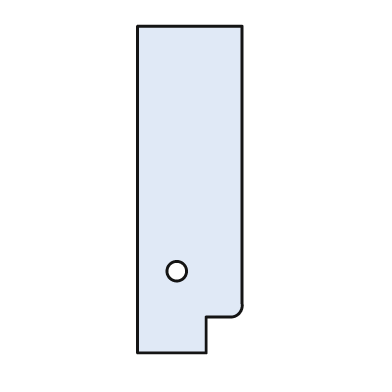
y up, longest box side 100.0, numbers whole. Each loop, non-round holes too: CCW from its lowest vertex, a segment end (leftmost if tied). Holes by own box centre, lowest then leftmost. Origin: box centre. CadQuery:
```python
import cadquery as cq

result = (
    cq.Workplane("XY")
    .moveTo(-16.0, -50.0)
    .lineTo(5.0, -50.0)
    .lineTo(5.0, -39.0)
    .lineTo(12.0, -39.0)
    .threePointArc((15.0, -38.0), (16.0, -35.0))
    .lineTo(16.0, 50.0)
    .lineTo(-16.0, 50.0)
    .close()
    .moveTo(-4.0, -25.0)
    .circle(3.0)
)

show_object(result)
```